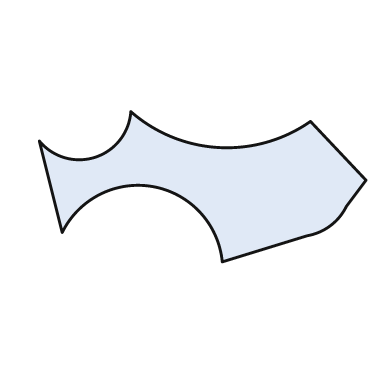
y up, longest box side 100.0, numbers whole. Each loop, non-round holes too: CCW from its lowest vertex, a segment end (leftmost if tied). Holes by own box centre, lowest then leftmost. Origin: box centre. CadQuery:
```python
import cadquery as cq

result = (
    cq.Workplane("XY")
    .moveTo(6.0, -23.0)
    .lineTo(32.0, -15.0)
    .threePointArc((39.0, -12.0), (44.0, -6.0))
    .lineTo(50.0, 2.0)
    .lineTo(33.0, 20.0)
    .threePointArc((5.0, 12.0), (-22.0, 23.0))
    .threePointArc((-33.0, 9.0), (-50.0, 14.0))
    .lineTo(-43.0, -14.0)
    .threePointArc((-15.0, 0.0), (6.0, -23.0))
    .close()
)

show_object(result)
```